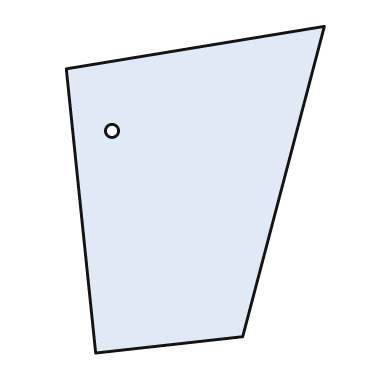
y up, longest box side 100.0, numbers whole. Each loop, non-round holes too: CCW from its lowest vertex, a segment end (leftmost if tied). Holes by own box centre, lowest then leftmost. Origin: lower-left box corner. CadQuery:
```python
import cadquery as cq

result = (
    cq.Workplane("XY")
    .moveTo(9.0, 0.0)
    .lineTo(54.0, 5.0)
    .lineTo(79.0, 100.0)
    .lineTo(0.0, 87.0)
    .close()
    .moveTo(14.0, 68.0)
    .circle(2.0)
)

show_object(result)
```